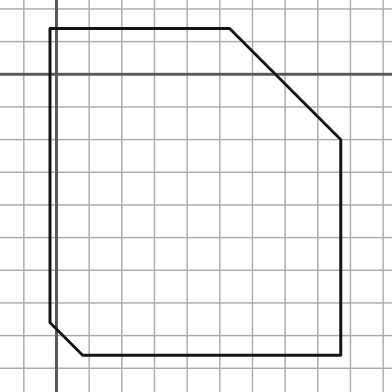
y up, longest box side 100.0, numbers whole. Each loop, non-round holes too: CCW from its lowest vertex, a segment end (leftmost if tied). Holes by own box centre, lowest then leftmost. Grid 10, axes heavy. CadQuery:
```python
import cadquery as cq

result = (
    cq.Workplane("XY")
    .moveTo(8.0, -86.0)
    .lineTo(87.0, -86.0)
    .lineTo(87.0, -20.0)
    .lineTo(53.0, 14.0)
    .lineTo(-2.0, 14.0)
    .lineTo(-2.0, -76.0)
    .close()
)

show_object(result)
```